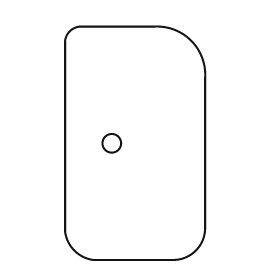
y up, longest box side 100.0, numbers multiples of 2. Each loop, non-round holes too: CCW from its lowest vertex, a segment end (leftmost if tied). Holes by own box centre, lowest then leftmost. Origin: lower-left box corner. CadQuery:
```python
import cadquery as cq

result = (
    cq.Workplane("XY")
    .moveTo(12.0, 0.0)
    .lineTo(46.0, 0.0)
    .threePointArc((56.0, 4.0), (60.0, 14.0))
    .lineTo(60.0, 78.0)
    .threePointArc((54.0, 94.0), (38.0, 100.0))
    .lineTo(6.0, 100.0)
    .threePointArc((2.0, 98.0), (0.0, 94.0))
    .lineTo(0.0, 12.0)
    .threePointArc((4.0, 4.0), (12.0, 0.0))
    .close()
    .moveTo(20.0, 50.0)
    .circle(4.0)
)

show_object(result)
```